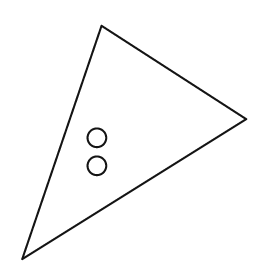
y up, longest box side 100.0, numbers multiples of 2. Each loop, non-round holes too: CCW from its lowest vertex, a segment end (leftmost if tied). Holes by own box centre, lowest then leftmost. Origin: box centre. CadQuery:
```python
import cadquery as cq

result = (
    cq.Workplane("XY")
    .moveTo(-48.0, -50.0)
    .lineTo(48.0, 10.0)
    .lineTo(-14.0, 50.0)
    .close()
    .moveTo(-16.0, -10.0)
    .circle(4.0)
    .moveTo(-16.0, 2.0)
    .circle(4.0)
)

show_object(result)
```